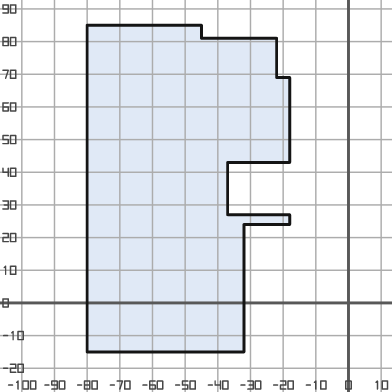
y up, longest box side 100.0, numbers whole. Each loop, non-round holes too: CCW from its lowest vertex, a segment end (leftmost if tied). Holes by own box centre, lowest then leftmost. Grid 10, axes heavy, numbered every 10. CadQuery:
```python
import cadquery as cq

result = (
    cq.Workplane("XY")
    .moveTo(-80.0, -15.0)
    .lineTo(-32.0, -15.0)
    .lineTo(-32.0, 24.0)
    .lineTo(-18.0, 24.0)
    .lineTo(-18.0, 27.0)
    .lineTo(-37.0, 27.0)
    .lineTo(-37.0, 43.0)
    .lineTo(-18.0, 43.0)
    .lineTo(-18.0, 69.0)
    .lineTo(-22.0, 69.0)
    .lineTo(-22.0, 81.0)
    .lineTo(-45.0, 81.0)
    .lineTo(-45.0, 85.0)
    .lineTo(-80.0, 85.0)
    .close()
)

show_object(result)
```